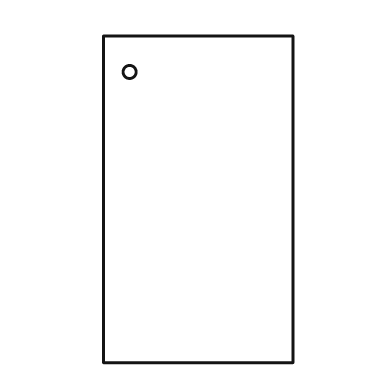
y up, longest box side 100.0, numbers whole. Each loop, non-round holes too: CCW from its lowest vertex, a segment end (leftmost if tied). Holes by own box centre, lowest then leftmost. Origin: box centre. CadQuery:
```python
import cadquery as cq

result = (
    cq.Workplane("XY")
    .moveTo(-29.0, -50.0)
    .lineTo(29.0, -50.0)
    .lineTo(29.0, 50.0)
    .lineTo(-29.0, 50.0)
    .close()
    .moveTo(-21.0, 39.0)
    .circle(2.0)
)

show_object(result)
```